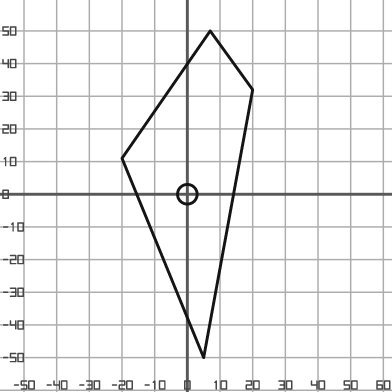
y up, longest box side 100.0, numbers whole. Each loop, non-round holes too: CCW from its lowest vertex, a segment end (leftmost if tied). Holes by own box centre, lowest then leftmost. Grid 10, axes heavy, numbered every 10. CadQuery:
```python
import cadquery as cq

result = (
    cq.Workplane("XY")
    .moveTo(5.0, -50.0)
    .lineTo(20.0, 32.0)
    .lineTo(7.0, 50.0)
    .lineTo(-20.0, 11.0)
    .close()
    .moveTo(0.0, 0.0)
    .circle(3.0)
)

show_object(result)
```